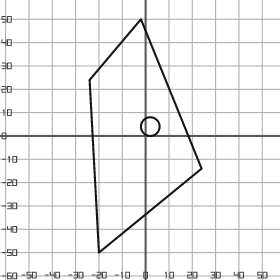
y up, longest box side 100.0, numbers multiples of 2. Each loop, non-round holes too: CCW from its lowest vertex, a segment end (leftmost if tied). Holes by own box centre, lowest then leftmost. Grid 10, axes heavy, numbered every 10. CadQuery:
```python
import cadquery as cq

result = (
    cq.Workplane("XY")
    .moveTo(-20.0, -50.0)
    .lineTo(24.0, -14.0)
    .lineTo(-2.0, 50.0)
    .lineTo(-24.0, 24.0)
    .close()
    .moveTo(2.0, 4.0)
    .circle(4.0)
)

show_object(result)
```